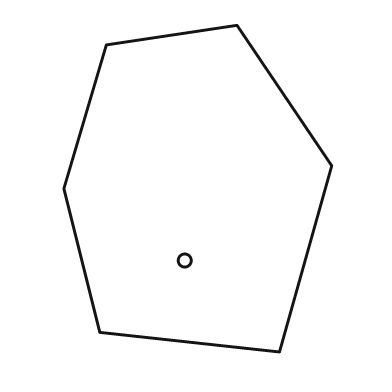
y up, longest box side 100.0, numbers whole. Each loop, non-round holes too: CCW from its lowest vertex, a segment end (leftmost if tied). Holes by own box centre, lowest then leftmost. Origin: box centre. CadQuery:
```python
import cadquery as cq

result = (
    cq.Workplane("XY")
    .moveTo(25.0, -50.0)
    .lineTo(41.0, 7.0)
    .lineTo(12.0, 50.0)
    .lineTo(-28.0, 44.0)
    .lineTo(-41.0, 0.0)
    .lineTo(-30.0, -44.0)
    .close()
    .moveTo(-4.0, -22.0)
    .circle(2.0)
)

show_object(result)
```